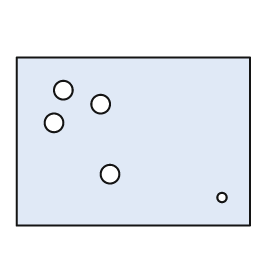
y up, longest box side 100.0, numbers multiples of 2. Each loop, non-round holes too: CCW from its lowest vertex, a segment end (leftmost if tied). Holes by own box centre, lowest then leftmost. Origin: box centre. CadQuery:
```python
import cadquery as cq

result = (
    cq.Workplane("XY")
    .moveTo(-50.0, -36.0)
    .lineTo(50.0, -36.0)
    .lineTo(50.0, 36.0)
    .lineTo(-50.0, 36.0)
    .close()
    .moveTo(38.0, -24.0)
    .circle(2.0)
    .moveTo(-10.0, -14.0)
    .circle(4.0)
    .moveTo(-34.0, 8.0)
    .circle(4.0)
    .moveTo(-14.0, 16.0)
    .circle(4.0)
    .moveTo(-30.0, 22.0)
    .circle(4.0)
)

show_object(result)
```